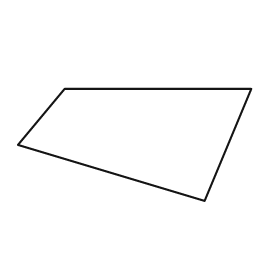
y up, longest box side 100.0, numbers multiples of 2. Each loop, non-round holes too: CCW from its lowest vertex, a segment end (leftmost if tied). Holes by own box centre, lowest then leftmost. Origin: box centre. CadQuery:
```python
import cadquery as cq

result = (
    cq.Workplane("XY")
    .moveTo(30.0, -24.0)
    .lineTo(50.0, 24.0)
    .lineTo(-30.0, 24.0)
    .lineTo(-50.0, 0.0)
    .close()
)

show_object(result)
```